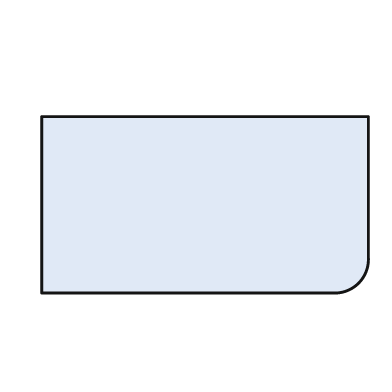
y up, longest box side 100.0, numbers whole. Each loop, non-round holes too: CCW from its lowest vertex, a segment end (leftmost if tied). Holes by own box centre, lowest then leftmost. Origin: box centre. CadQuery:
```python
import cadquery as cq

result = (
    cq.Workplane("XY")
    .moveTo(-50.0, -27.0)
    .lineTo(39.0, -27.0)
    .threePointArc((47.0, -24.0), (50.0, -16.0))
    .lineTo(50.0, 27.0)
    .lineTo(-50.0, 27.0)
    .close()
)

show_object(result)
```